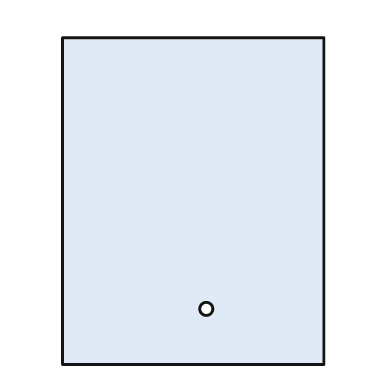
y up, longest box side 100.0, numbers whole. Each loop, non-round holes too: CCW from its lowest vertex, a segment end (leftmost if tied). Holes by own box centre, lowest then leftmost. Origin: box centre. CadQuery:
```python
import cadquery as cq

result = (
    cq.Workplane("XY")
    .moveTo(-40.0, -50.0)
    .lineTo(40.0, -50.0)
    .lineTo(40.0, 50.0)
    .lineTo(-40.0, 50.0)
    .close()
    .moveTo(4.0, -33.0)
    .circle(2.0)
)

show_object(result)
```